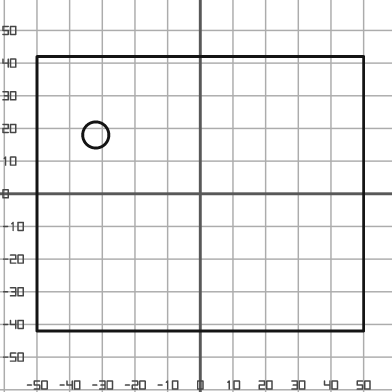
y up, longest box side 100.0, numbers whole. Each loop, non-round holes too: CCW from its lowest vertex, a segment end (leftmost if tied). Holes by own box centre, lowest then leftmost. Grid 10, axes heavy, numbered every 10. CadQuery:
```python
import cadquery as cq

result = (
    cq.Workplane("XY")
    .moveTo(-50.0, -42.0)
    .lineTo(50.0, -42.0)
    .lineTo(50.0, 42.0)
    .lineTo(-50.0, 42.0)
    .close()
    .moveTo(-32.0, 18.0)
    .circle(4.0)
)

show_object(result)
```